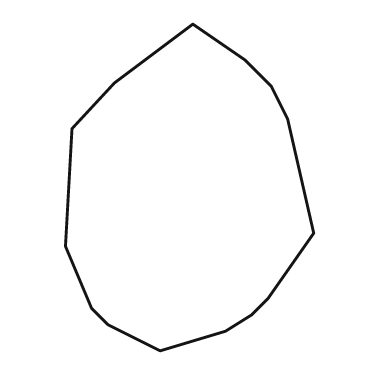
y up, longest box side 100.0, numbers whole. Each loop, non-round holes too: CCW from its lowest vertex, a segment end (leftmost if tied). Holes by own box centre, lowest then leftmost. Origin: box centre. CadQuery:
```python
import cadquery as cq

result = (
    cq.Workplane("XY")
    .moveTo(-9.0, -50.0)
    .lineTo(11.0, -44.0)
    .lineTo(19.0, -39.0)
    .lineTo(24.0, -34.0)
    .lineTo(38.0, -14.0)
    .lineTo(30.0, 21.0)
    .lineTo(25.0, 31.0)
    .lineTo(17.0, 39.0)
    .lineTo(1.0, 50.0)
    .lineTo(-23.0, 32.0)
    .lineTo(-36.0, 18.0)
    .lineTo(-38.0, -18.0)
    .lineTo(-30.0, -37.0)
    .lineTo(-25.0, -42.0)
    .close()
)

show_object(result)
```